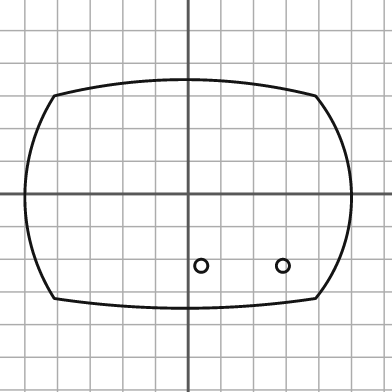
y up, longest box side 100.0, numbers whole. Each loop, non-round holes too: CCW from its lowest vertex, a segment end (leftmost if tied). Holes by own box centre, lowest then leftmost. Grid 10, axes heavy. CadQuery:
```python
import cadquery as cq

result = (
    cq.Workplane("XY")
    .moveTo(-41.0, -32.0)
    .threePointArc((-1.0, -35.0), (39.0, -32.0))
    .threePointArc((50.0, -1.0), (39.0, 30.0))
    .threePointArc((-1.0, 35.0), (-41.0, 30.0))
    .threePointArc((-50.0, -1.0), (-41.0, -32.0))
    .close()
    .moveTo(4.0, -22.0)
    .circle(2.0)
    .moveTo(29.0, -22.0)
    .circle(2.0)
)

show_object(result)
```